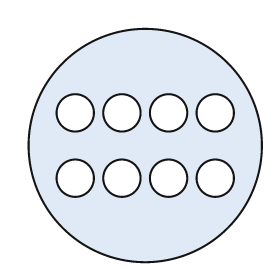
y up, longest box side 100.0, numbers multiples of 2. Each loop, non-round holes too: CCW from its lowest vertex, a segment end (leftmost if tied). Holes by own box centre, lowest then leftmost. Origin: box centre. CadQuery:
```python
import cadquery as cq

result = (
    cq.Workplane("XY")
    .moveTo(0.0, 0.0)
    .circle(50.0)
    .moveTo(-30.0, -14.0)
    .circle(8.0)
    .moveTo(-10.0, -14.0)
    .circle(8.0)
    .moveTo(10.0, -14.0)
    .circle(8.0)
    .moveTo(30.0, -14.0)
    .circle(8.0)
    .moveTo(-30.0, 14.0)
    .circle(8.0)
    .moveTo(-10.0, 14.0)
    .circle(8.0)
    .moveTo(10.0, 14.0)
    .circle(8.0)
    .moveTo(30.0, 14.0)
    .circle(8.0)
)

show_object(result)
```